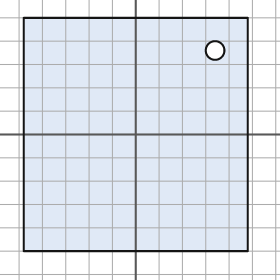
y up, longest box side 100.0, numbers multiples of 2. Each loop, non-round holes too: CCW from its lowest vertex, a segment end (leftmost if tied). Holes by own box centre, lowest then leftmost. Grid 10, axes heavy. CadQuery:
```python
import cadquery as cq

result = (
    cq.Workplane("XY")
    .moveTo(-48.0, -50.0)
    .lineTo(48.0, -50.0)
    .lineTo(48.0, 50.0)
    .lineTo(-48.0, 50.0)
    .close()
    .moveTo(34.0, 36.0)
    .circle(4.0)
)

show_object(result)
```